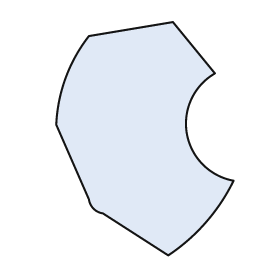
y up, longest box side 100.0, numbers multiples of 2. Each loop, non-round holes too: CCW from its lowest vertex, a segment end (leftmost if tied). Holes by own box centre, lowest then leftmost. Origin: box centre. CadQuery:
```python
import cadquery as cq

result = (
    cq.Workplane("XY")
    .moveTo(10.0, -50.0)
    .threePointArc((26.0, -36.0), (38.0, -18.0))
    .threePointArc((18.0, 2.0), (30.0, 28.0))
    .lineTo(12.0, 50.0)
    .lineTo(-24.0, 44.0)
    .threePointArc((-34.0, 26.0), (-38.0, 6.0))
    .lineTo(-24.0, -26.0)
    .threePointArc((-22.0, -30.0), (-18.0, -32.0))
    .close()
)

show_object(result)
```